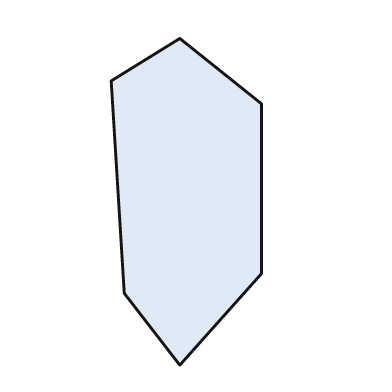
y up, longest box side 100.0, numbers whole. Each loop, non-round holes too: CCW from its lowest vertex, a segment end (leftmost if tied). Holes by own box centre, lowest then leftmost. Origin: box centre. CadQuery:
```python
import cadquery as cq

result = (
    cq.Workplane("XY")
    .moveTo(-2.0, -50.0)
    .lineTo(23.0, -22.0)
    .lineTo(23.0, 30.0)
    .lineTo(-2.0, 50.0)
    .lineTo(-23.0, 37.0)
    .lineTo(-19.0, -28.0)
    .close()
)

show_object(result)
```